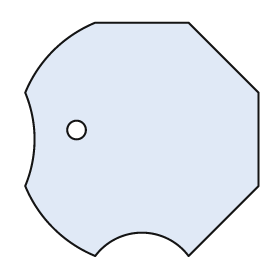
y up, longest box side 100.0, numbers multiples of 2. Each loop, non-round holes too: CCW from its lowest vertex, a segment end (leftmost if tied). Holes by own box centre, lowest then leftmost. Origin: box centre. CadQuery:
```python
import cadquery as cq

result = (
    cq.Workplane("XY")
    .moveTo(-20.0, -50.0)
    .threePointArc((0.0, -40.0), (20.0, -50.0))
    .lineTo(50.0, -20.0)
    .lineTo(50.0, 20.0)
    .lineTo(20.0, 50.0)
    .lineTo(-20.0, 50.0)
    .threePointArc((-38.0, 38.0), (-50.0, 20.0))
    .threePointArc((-46.0, 0.0), (-50.0, -20.0))
    .threePointArc((-38.0, -38.0), (-20.0, -50.0))
    .close()
    .moveTo(-28.0, 4.0)
    .circle(4.0)
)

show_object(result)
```